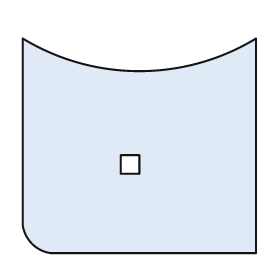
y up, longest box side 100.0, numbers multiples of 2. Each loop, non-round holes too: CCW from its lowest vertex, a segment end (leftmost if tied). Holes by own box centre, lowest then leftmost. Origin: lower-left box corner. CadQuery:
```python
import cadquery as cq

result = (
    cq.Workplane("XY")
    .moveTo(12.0, 0.0)
    .lineTo(100.0, 0.0)
    .lineTo(100.0, 92.0)
    .threePointArc((50.0, 78.0), (0.0, 92.0))
    .lineTo(0.0, 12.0)
    .threePointArc((4.0, 4.0), (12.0, 0.0))
    .close()
    .moveTo(42.0, 34.0)
    .lineTo(50.0, 34.0)
    .lineTo(50.0, 42.0)
    .lineTo(42.0, 42.0)
    .close()
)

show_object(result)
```